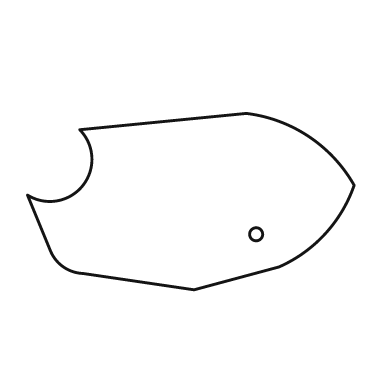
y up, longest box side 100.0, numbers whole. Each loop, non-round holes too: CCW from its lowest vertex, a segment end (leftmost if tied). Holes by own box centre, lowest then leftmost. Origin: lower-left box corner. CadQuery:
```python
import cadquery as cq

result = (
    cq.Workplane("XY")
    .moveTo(51.0, 0.0)
    .lineTo(77.0, 7.0)
    .threePointArc((91.0, 17.0), (100.0, 32.0))
    .threePointArc((86.0, 47.0), (67.0, 54.0))
    .lineTo(16.0, 49.0)
    .threePointArc((17.0, 32.0), (0.0, 29.0))
    .lineTo(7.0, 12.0)
    .threePointArc((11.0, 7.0), (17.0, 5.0))
    .close()
    .moveTo(70.0, 17.0)
    .circle(2.0)
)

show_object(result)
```